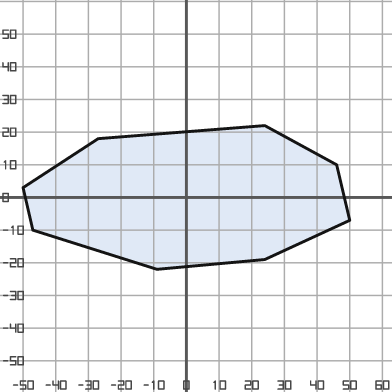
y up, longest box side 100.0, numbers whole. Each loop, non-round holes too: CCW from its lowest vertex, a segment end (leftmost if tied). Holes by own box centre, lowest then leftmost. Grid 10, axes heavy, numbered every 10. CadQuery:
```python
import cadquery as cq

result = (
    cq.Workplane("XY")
    .moveTo(-9.0, -22.0)
    .lineTo(24.0, -19.0)
    .lineTo(50.0, -7.0)
    .lineTo(46.0, 10.0)
    .lineTo(24.0, 22.0)
    .lineTo(-27.0, 18.0)
    .lineTo(-50.0, 3.0)
    .lineTo(-47.0, -10.0)
    .close()
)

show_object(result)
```